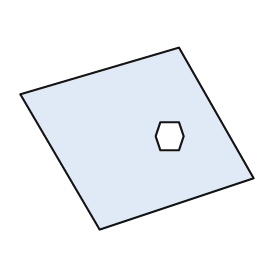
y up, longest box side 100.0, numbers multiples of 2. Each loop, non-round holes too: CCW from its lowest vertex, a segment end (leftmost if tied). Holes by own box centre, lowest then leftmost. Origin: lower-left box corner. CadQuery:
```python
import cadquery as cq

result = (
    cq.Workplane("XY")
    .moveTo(34.0, 0.0)
    .lineTo(100.0, 22.0)
    .lineTo(68.0, 78.0)
    .lineTo(0.0, 58.0)
    .close()
    .moveTo(60.0, 34.0)
    .lineTo(68.0, 34.0)
    .lineTo(70.0, 40.0)
    .lineTo(68.0, 46.0)
    .lineTo(60.0, 46.0)
    .lineTo(58.0, 40.0)
    .close()
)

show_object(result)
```